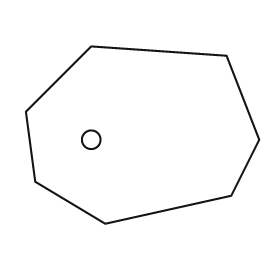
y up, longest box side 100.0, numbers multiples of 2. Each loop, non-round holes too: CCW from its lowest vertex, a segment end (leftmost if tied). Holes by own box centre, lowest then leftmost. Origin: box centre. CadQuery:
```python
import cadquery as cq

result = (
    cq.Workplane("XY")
    .moveTo(-16.0, -38.0)
    .lineTo(38.0, -26.0)
    .lineTo(50.0, -2.0)
    .lineTo(36.0, 34.0)
    .lineTo(-22.0, 38.0)
    .lineTo(-50.0, 10.0)
    .lineTo(-46.0, -20.0)
    .close()
    .moveTo(-22.0, -2.0)
    .circle(4.0)
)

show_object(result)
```